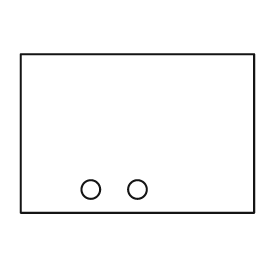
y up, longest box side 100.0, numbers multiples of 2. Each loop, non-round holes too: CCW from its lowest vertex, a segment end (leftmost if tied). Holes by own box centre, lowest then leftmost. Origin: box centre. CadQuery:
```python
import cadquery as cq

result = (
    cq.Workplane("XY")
    .moveTo(-50.0, -34.0)
    .lineTo(50.0, -34.0)
    .lineTo(50.0, 34.0)
    .lineTo(-50.0, 34.0)
    .close()
    .moveTo(-20.0, -24.0)
    .circle(4.0)
    .moveTo(0.0, -24.0)
    .circle(4.0)
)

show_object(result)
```